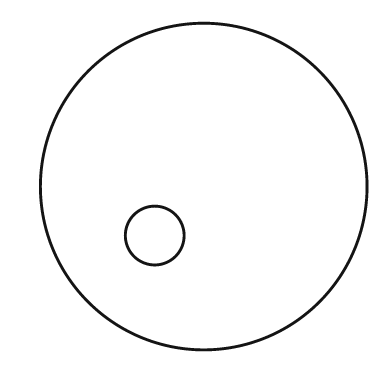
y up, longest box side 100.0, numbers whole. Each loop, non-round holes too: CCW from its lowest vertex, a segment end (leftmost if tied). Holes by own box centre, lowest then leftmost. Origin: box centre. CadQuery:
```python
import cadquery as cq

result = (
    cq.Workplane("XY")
    .moveTo(0.0, 0.0)
    .circle(50.0)
    .moveTo(-15.0, -15.0)
    .circle(9.0)
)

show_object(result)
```